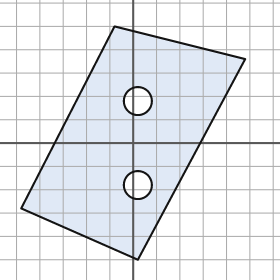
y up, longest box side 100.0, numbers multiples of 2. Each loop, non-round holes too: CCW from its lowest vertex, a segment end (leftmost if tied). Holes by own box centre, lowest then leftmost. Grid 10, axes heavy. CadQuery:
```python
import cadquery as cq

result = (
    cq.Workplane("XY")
    .moveTo(2.0, -50.0)
    .lineTo(48.0, 36.0)
    .lineTo(-8.0, 50.0)
    .lineTo(-48.0, -28.0)
    .close()
    .moveTo(2.0, -18.0)
    .circle(6.0)
    .moveTo(2.0, 18.0)
    .circle(6.0)
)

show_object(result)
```